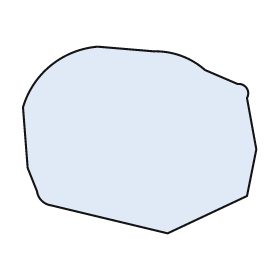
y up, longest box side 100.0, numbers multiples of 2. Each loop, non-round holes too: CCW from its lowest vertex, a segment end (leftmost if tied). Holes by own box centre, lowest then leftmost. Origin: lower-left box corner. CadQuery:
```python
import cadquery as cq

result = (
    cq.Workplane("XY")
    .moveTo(62.0, 0.0)
    .lineTo(96.0, 16.0)
    .lineTo(100.0, 36.0)
    .lineTo(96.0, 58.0)
    .threePointArc((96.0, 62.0), (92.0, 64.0))
    .lineTo(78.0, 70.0)
    .threePointArc((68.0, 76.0), (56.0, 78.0))
    .lineTo(32.0, 80.0)
    .threePointArc((12.0, 72.0), (0.0, 54.0))
    .lineTo(2.0, 28.0)
    .lineTo(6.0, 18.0)
    .threePointArc((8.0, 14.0), (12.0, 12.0))
    .close()
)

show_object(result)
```